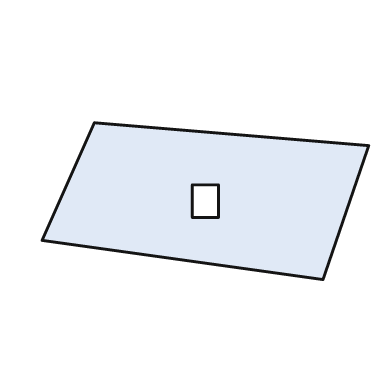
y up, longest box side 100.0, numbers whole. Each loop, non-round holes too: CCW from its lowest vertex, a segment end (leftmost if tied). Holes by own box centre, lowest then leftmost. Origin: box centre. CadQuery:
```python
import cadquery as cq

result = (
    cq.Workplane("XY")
    .moveTo(36.0, -24.0)
    .lineTo(50.0, 17.0)
    .lineTo(-34.0, 24.0)
    .lineTo(-50.0, -12.0)
    .close()
    .moveTo(-4.0, -5.0)
    .lineTo(4.0, -5.0)
    .lineTo(4.0, 5.0)
    .lineTo(-4.0, 5.0)
    .close()
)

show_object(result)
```